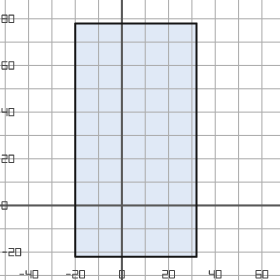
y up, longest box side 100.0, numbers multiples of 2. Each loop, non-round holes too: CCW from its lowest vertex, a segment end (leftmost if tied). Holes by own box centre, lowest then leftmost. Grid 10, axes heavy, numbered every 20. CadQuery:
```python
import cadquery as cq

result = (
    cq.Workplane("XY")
    .moveTo(-20.0, -22.0)
    .lineTo(32.0, -22.0)
    .lineTo(32.0, 78.0)
    .lineTo(-20.0, 78.0)
    .close()
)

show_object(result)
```